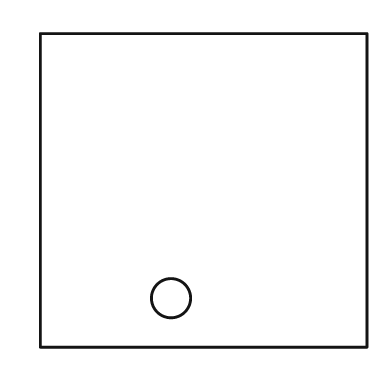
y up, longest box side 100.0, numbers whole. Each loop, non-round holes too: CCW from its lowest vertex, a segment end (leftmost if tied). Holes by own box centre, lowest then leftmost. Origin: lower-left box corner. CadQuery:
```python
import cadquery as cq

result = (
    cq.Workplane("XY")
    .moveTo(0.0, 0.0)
    .lineTo(100.0, 0.0)
    .lineTo(100.0, 96.0)
    .lineTo(0.0, 96.0)
    .close()
    .moveTo(40.0, 15.0)
    .circle(6.0)
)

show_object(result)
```